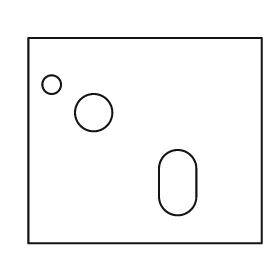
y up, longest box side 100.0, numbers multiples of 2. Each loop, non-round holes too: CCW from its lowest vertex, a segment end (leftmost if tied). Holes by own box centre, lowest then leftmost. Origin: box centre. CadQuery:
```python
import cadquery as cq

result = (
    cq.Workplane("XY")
    .moveTo(-50.0, -44.0)
    .lineTo(50.0, -44.0)
    .lineTo(50.0, 44.0)
    .lineTo(-50.0, 44.0)
    .close()
    .moveTo(6.0, -24.0)
    .threePointArc((14.0, -32.0), (22.0, -24.0))
    .lineTo(22.0, -12.0)
    .threePointArc((14.0, -4.0), (6.0, -12.0))
    .close()
    .moveTo(-22.0, 12.0)
    .circle(8.0)
    .moveTo(-40.0, 24.0)
    .circle(4.0)
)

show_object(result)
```